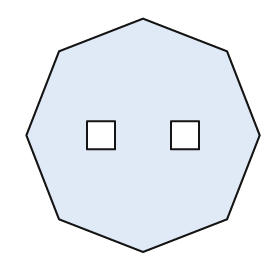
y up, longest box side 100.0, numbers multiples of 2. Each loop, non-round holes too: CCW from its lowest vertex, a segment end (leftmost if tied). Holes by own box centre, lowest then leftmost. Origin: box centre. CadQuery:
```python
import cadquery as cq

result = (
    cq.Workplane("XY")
    .moveTo(0.0, -50.0)
    .lineTo(36.0, -36.0)
    .lineTo(50.0, 0.0)
    .lineTo(36.0, 36.0)
    .lineTo(0.0, 50.0)
    .lineTo(-36.0, 36.0)
    .lineTo(-50.0, 0.0)
    .lineTo(-36.0, -36.0)
    .close()
    .moveTo(-24.0, -6.0)
    .lineTo(-12.0, -6.0)
    .lineTo(-12.0, 6.0)
    .lineTo(-24.0, 6.0)
    .close()
    .moveTo(12.0, -6.0)
    .lineTo(24.0, -6.0)
    .lineTo(24.0, 6.0)
    .lineTo(12.0, 6.0)
    .close()
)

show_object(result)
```